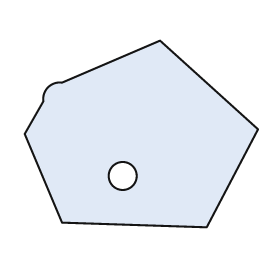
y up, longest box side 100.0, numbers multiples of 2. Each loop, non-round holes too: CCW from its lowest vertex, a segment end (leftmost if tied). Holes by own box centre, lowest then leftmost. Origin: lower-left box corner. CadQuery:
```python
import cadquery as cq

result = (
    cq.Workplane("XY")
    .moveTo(78.0, 0.0)
    .lineTo(100.0, 42.0)
    .lineTo(58.0, 80.0)
    .lineTo(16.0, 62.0)
    .threePointArc((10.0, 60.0), (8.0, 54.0))
    .lineTo(0.0, 40.0)
    .lineTo(16.0, 2.0)
    .close()
    .moveTo(42.0, 22.0)
    .circle(6.0)
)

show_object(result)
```